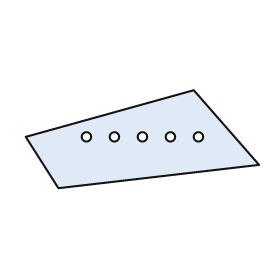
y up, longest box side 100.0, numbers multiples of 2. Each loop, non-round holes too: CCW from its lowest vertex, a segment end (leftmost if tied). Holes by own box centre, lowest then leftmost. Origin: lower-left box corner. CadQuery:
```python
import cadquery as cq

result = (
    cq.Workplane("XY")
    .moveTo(14.0, 0.0)
    .lineTo(100.0, 10.0)
    .lineTo(72.0, 42.0)
    .lineTo(0.0, 22.0)
    .close()
    .moveTo(26.0, 22.0)
    .circle(2.0)
    .moveTo(38.0, 22.0)
    .circle(2.0)
    .moveTo(50.0, 22.0)
    .circle(2.0)
    .moveTo(62.0, 22.0)
    .circle(2.0)
    .moveTo(74.0, 22.0)
    .circle(2.0)
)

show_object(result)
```